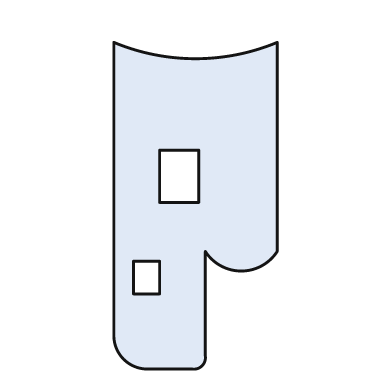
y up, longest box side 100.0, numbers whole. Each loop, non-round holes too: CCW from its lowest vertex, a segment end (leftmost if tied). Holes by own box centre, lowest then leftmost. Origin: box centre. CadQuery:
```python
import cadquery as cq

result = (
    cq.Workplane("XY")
    .moveTo(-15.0, -50.0)
    .lineTo(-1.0, -50.0)
    .threePointArc((2.0, -49.0), (3.0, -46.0))
    .lineTo(3.0, -14.0)
    .threePointArc((14.0, -20.0), (25.0, -14.0))
    .lineTo(25.0, 50.0)
    .threePointArc((0.0, 45.0), (-25.0, 50.0))
    .lineTo(-25.0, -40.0)
    .threePointArc((-22.0, -47.0), (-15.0, -50.0))
    .close()
    .moveTo(-19.0, -27.0)
    .lineTo(-11.0, -27.0)
    .lineTo(-11.0, -17.0)
    .lineTo(-19.0, -17.0)
    .close()
    .moveTo(-11.0, 1.0)
    .lineTo(1.0, 1.0)
    .lineTo(1.0, 17.0)
    .lineTo(-11.0, 17.0)
    .close()
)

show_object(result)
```